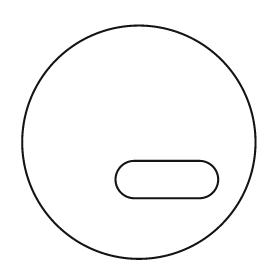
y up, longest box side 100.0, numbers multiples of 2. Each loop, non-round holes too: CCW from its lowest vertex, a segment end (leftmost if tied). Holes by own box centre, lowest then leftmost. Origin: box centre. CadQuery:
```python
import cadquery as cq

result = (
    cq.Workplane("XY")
    .moveTo(0.0, 0.0)
    .circle(50.0)
    .moveTo(-2.0, -24.0)
    .lineTo(26.0, -24.0)
    .threePointArc((34.0, -16.0), (26.0, -8.0))
    .lineTo(-2.0, -8.0)
    .threePointArc((-10.0, -16.0), (-2.0, -24.0))
    .close()
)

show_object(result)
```